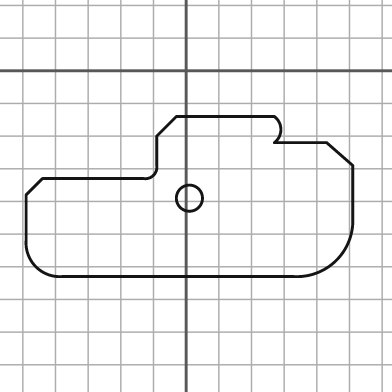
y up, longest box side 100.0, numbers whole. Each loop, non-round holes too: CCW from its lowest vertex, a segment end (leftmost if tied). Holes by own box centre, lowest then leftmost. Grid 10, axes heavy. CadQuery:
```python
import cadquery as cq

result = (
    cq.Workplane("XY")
    .moveTo(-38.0, -63.0)
    .lineTo(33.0, -63.0)
    .threePointArc((46.0, -58.0), (51.0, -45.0))
    .lineTo(51.0, -29.0)
    .lineTo(43.0, -22.0)
    .lineTo(27.0, -22.0)
    .threePointArc((29.0, -18.0), (27.0, -14.0))
    .lineTo(-3.0, -14.0)
    .lineTo(-9.0, -20.0)
    .lineTo(-9.0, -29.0)
    .threePointArc((-10.0, -32.0), (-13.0, -33.0))
    .lineTo(-44.0, -33.0)
    .lineTo(-49.0, -38.0)
    .lineTo(-49.0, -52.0)
    .threePointArc((-46.0, -60.0), (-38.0, -63.0))
    .close()
    .moveTo(1.0, -39.0)
    .circle(4.0)
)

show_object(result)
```